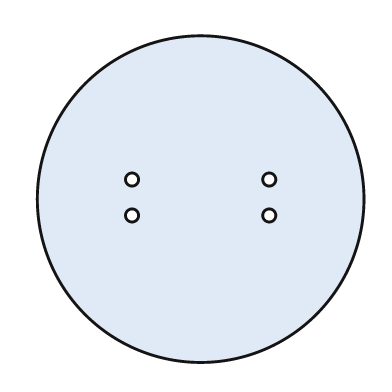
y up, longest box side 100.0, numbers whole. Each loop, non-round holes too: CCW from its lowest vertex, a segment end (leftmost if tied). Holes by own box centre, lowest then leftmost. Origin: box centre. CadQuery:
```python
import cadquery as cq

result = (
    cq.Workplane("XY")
    .moveTo(0.0, 0.0)
    .circle(50.0)
    .moveTo(-21.0, -5.0)
    .circle(2.0)
    .moveTo(21.0, -5.0)
    .circle(2.0)
    .moveTo(-21.0, 6.0)
    .circle(2.0)
    .moveTo(21.0, 6.0)
    .circle(2.0)
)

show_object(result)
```